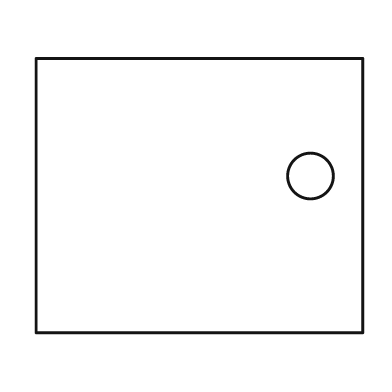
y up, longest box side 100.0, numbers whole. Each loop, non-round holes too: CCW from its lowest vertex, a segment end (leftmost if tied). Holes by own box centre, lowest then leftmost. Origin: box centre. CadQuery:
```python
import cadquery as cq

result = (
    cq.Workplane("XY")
    .moveTo(-50.0, -42.0)
    .lineTo(50.0, -42.0)
    .lineTo(50.0, 42.0)
    .lineTo(-50.0, 42.0)
    .close()
    .moveTo(34.0, 6.0)
    .circle(7.0)
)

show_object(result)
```